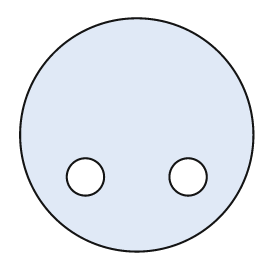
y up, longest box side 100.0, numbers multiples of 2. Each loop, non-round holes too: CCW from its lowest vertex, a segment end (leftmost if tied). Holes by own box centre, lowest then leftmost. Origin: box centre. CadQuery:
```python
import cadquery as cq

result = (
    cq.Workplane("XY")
    .moveTo(0.0, 0.0)
    .circle(50.0)
    .moveTo(-22.0, -18.0)
    .circle(8.0)
    .moveTo(22.0, -18.0)
    .circle(8.0)
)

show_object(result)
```